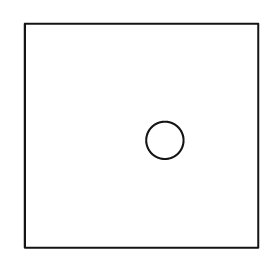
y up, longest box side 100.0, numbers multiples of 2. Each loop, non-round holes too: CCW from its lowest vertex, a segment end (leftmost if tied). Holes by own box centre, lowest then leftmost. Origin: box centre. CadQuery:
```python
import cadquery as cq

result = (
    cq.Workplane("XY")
    .moveTo(-50.0, -48.0)
    .lineTo(50.0, -48.0)
    .lineTo(50.0, 48.0)
    .lineTo(-50.0, 48.0)
    .close()
    .moveTo(10.0, -2.0)
    .circle(8.0)
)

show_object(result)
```